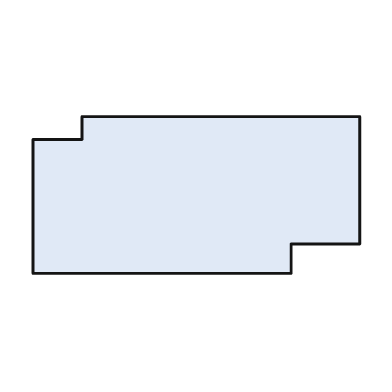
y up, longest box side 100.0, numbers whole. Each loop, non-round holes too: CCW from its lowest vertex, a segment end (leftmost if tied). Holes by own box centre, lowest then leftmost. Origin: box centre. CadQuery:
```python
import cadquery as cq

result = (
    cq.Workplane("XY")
    .moveTo(-50.0, -24.0)
    .lineTo(29.0, -24.0)
    .lineTo(29.0, -15.0)
    .lineTo(50.0, -15.0)
    .lineTo(50.0, 24.0)
    .lineTo(-35.0, 24.0)
    .lineTo(-35.0, 17.0)
    .lineTo(-50.0, 17.0)
    .close()
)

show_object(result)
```